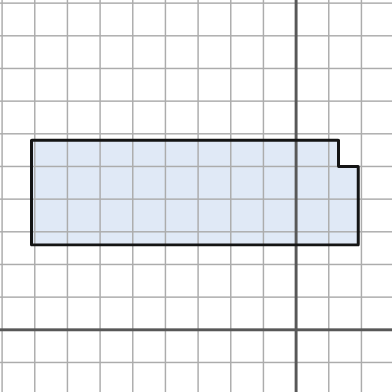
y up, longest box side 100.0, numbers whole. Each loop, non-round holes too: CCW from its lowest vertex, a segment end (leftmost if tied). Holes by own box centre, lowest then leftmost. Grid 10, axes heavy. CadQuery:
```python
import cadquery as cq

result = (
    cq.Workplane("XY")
    .moveTo(-81.0, 26.0)
    .lineTo(19.0, 26.0)
    .lineTo(19.0, 50.0)
    .lineTo(13.0, 50.0)
    .lineTo(13.0, 58.0)
    .lineTo(-81.0, 58.0)
    .close()
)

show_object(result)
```